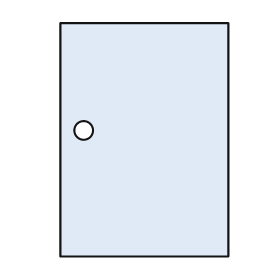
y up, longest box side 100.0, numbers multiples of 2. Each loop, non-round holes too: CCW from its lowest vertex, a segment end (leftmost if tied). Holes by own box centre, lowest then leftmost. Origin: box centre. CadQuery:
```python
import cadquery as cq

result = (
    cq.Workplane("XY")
    .moveTo(-36.0, -50.0)
    .lineTo(36.0, -50.0)
    .lineTo(36.0, 50.0)
    .lineTo(-36.0, 50.0)
    .close()
    .moveTo(-26.0, 4.0)
    .circle(4.0)
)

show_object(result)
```